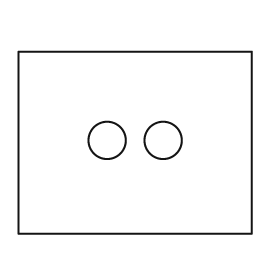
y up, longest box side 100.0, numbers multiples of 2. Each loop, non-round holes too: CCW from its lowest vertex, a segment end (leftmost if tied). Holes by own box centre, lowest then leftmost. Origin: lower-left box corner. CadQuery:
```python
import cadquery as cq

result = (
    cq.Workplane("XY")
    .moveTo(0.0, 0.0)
    .lineTo(100.0, 0.0)
    .lineTo(100.0, 78.0)
    .lineTo(0.0, 78.0)
    .close()
    .moveTo(38.0, 40.0)
    .circle(8.0)
    .moveTo(62.0, 40.0)
    .circle(8.0)
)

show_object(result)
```